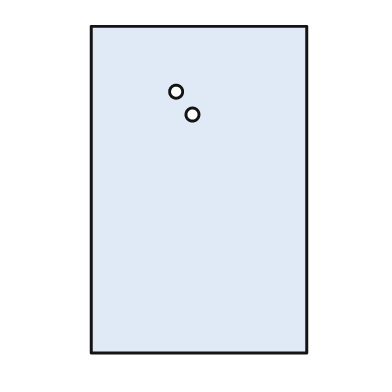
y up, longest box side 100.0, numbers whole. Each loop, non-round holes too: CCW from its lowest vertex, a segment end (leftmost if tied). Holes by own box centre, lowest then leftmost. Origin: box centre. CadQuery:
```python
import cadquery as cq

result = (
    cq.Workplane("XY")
    .moveTo(-33.0, -50.0)
    .lineTo(33.0, -50.0)
    .lineTo(33.0, 50.0)
    .lineTo(-33.0, 50.0)
    .close()
    .moveTo(-2.0, 23.0)
    .circle(2.0)
    .moveTo(-7.0, 30.0)
    .circle(2.0)
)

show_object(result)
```